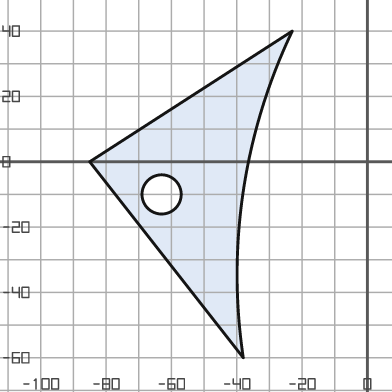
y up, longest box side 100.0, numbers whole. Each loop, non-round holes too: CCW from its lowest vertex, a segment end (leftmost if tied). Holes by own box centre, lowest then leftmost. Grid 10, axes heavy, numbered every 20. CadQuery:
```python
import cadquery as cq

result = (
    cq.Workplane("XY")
    .moveTo(-38.0, -60.0)
    .threePointArc((-38.0, -9.0), (-23.0, 40.0))
    .lineTo(-85.0, 0.0)
    .close()
    .moveTo(-63.0, -10.0)
    .circle(6.0)
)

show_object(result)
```